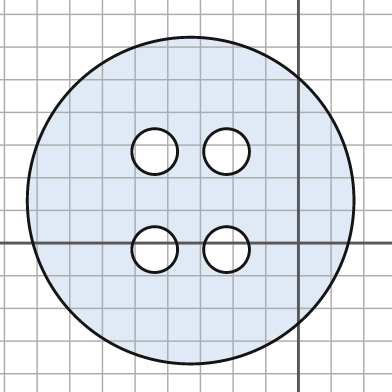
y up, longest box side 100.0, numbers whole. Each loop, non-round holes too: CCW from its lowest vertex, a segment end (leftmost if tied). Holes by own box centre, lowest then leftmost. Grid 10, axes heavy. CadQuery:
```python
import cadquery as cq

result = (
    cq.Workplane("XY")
    .moveTo(-33.0, 13.0)
    .circle(50.0)
    .moveTo(-44.0, -2.0)
    .circle(7.0)
    .moveTo(-22.0, -2.0)
    .circle(7.0)
    .moveTo(-44.0, 28.0)
    .circle(7.0)
    .moveTo(-22.0, 28.0)
    .circle(7.0)
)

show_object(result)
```